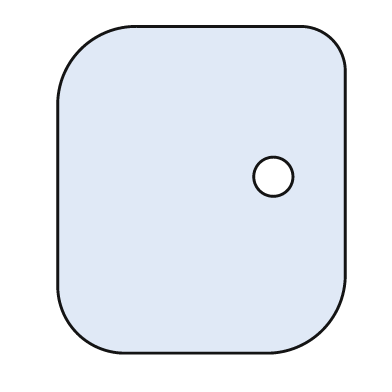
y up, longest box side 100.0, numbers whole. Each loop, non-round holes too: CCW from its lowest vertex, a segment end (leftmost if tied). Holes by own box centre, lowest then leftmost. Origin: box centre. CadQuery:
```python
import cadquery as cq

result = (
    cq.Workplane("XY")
    .moveTo(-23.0, -50.0)
    .lineTo(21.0, -50.0)
    .threePointArc((37.0, -43.0), (44.0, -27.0))
    .lineTo(44.0, 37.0)
    .threePointArc((40.0, 46.0), (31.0, 50.0))
    .lineTo(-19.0, 50.0)
    .threePointArc((-37.0, 43.0), (-44.0, 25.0))
    .lineTo(-44.0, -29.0)
    .threePointArc((-38.0, -44.0), (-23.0, -50.0))
    .close()
    .moveTo(22.0, 4.0)
    .circle(6.0)
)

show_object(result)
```